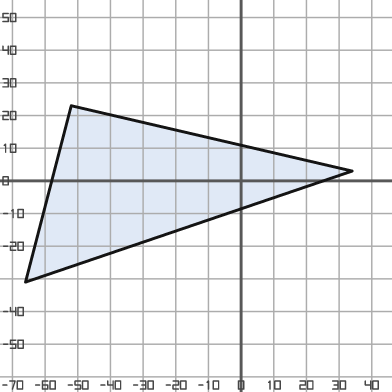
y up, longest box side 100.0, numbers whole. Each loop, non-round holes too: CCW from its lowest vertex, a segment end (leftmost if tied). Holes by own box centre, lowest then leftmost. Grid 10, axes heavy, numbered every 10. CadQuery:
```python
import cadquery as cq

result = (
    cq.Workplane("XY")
    .moveTo(-66.0, -31.0)
    .lineTo(34.0, 3.0)
    .lineTo(-52.0, 23.0)
    .close()
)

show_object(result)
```